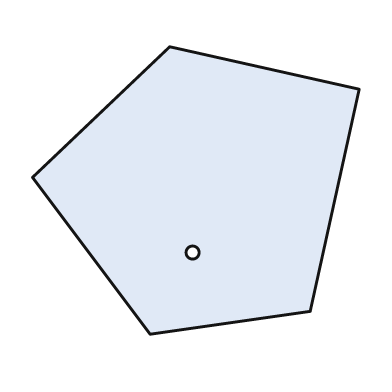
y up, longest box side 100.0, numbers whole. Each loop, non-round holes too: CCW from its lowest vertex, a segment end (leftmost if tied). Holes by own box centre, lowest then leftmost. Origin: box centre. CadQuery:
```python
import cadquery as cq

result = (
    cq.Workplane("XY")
    .moveTo(-14.0, -44.0)
    .lineTo(35.0, -37.0)
    .lineTo(50.0, 31.0)
    .lineTo(-8.0, 44.0)
    .lineTo(-50.0, 4.0)
    .close()
    .moveTo(-1.0, -19.0)
    .circle(2.0)
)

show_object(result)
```